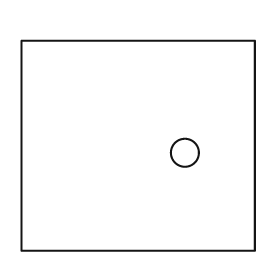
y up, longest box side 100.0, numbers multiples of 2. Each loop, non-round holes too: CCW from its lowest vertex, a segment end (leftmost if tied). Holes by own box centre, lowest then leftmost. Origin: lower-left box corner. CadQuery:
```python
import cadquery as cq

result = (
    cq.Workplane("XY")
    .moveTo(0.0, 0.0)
    .lineTo(100.0, 0.0)
    .lineTo(100.0, 90.0)
    .lineTo(0.0, 90.0)
    .close()
    .moveTo(70.0, 42.0)
    .circle(6.0)
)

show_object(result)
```